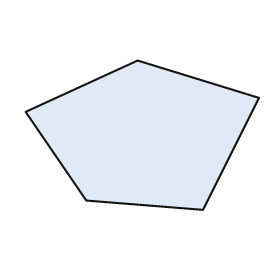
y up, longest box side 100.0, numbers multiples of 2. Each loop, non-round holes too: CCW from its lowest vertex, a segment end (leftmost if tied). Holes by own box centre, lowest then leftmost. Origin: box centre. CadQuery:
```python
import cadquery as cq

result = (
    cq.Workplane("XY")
    .moveTo(26.0, -32.0)
    .lineTo(50.0, 16.0)
    .lineTo(-2.0, 32.0)
    .lineTo(-50.0, 10.0)
    .lineTo(-24.0, -28.0)
    .close()
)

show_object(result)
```